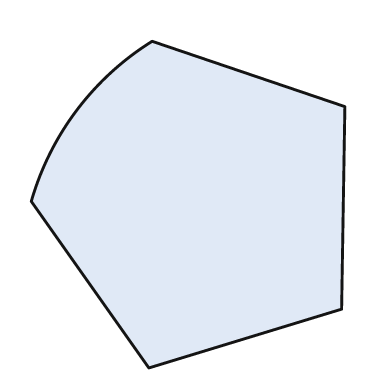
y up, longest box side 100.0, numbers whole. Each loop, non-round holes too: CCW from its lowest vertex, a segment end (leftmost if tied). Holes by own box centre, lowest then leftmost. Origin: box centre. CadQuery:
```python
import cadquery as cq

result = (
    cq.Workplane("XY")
    .moveTo(-12.0, -50.0)
    .lineTo(47.0, -32.0)
    .lineTo(48.0, 30.0)
    .lineTo(-11.0, 50.0)
    .threePointArc((-34.0, 29.0), (-48.0, 1.0))
    .close()
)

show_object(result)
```